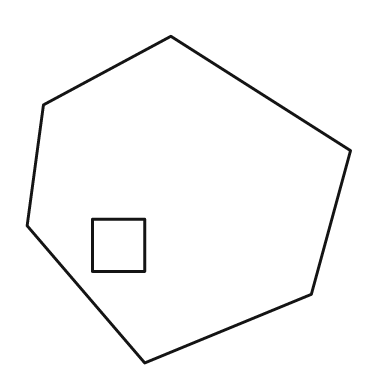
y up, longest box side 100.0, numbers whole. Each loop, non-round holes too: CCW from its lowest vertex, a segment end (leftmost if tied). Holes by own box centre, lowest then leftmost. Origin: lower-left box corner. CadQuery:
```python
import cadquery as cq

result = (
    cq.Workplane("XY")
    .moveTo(36.0, 0.0)
    .lineTo(87.0, 21.0)
    .lineTo(99.0, 65.0)
    .lineTo(44.0, 100.0)
    .lineTo(5.0, 79.0)
    .lineTo(0.0, 42.0)
    .close()
    .moveTo(20.0, 28.0)
    .lineTo(36.0, 28.0)
    .lineTo(36.0, 44.0)
    .lineTo(20.0, 44.0)
    .close()
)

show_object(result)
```